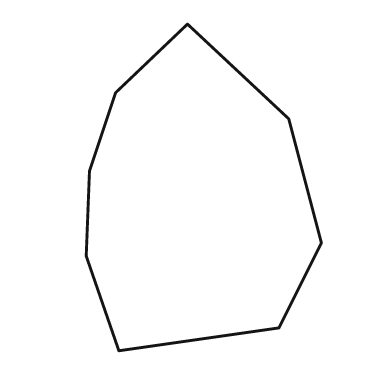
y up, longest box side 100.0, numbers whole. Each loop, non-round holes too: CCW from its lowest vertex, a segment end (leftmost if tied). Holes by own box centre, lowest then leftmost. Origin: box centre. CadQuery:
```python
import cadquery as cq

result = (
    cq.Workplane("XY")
    .moveTo(-26.0, -50.0)
    .lineTo(23.0, -43.0)
    .lineTo(36.0, -17.0)
    .lineTo(26.0, 21.0)
    .lineTo(-5.0, 50.0)
    .lineTo(-27.0, 29.0)
    .lineTo(-35.0, 5.0)
    .lineTo(-36.0, -21.0)
    .close()
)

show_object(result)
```